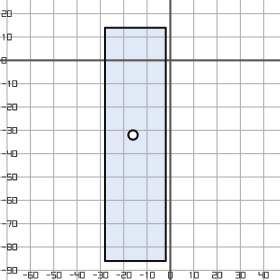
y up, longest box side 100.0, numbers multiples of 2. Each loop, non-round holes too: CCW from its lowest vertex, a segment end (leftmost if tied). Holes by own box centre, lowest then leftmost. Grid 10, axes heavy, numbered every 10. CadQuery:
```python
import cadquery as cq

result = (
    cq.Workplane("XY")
    .moveTo(-28.0, -86.0)
    .lineTo(-2.0, -86.0)
    .lineTo(-2.0, 14.0)
    .lineTo(-28.0, 14.0)
    .close()
    .moveTo(-16.0, -32.0)
    .circle(2.0)
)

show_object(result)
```